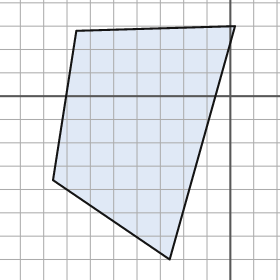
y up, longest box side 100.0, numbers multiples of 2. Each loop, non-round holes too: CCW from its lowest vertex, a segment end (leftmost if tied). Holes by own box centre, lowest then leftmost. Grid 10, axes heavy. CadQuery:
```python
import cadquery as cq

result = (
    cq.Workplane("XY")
    .moveTo(-26.0, -70.0)
    .lineTo(2.0, 30.0)
    .lineTo(-66.0, 28.0)
    .lineTo(-76.0, -36.0)
    .close()
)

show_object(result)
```